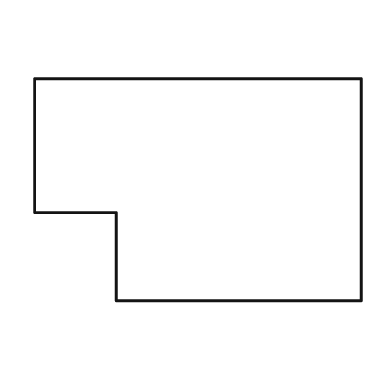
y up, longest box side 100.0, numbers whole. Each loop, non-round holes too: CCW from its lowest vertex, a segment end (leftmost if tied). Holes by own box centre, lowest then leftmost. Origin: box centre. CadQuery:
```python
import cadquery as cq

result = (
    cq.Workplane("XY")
    .moveTo(-25.0, -34.0)
    .lineTo(50.0, -34.0)
    .lineTo(50.0, 34.0)
    .lineTo(-50.0, 34.0)
    .lineTo(-50.0, -7.0)
    .lineTo(-25.0, -7.0)
    .close()
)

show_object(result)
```